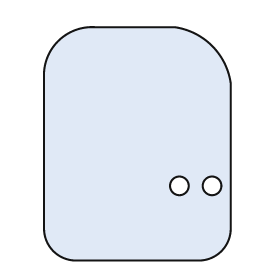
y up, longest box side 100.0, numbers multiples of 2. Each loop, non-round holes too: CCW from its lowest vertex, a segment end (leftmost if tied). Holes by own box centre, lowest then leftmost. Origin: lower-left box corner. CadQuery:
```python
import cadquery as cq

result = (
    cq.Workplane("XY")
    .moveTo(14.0, 0.0)
    .lineTo(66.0, 0.0)
    .threePointArc((76.0, 4.0), (80.0, 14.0))
    .lineTo(80.0, 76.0)
    .threePointArc((72.0, 92.0), (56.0, 100.0))
    .lineTo(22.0, 100.0)
    .threePointArc((6.0, 94.0), (0.0, 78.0))
    .lineTo(0.0, 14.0)
    .threePointArc((4.0, 4.0), (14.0, 0.0))
    .close()
    .moveTo(58.0, 32.0)
    .circle(4.0)
    .moveTo(72.0, 32.0)
    .circle(4.0)
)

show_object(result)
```